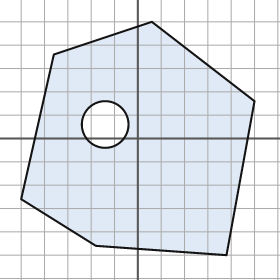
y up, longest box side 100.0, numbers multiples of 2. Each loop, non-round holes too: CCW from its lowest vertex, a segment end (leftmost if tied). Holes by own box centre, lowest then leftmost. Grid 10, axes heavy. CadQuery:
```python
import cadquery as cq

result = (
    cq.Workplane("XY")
    .moveTo(38.0, -50.0)
    .lineTo(50.0, 16.0)
    .lineTo(6.0, 50.0)
    .lineTo(-36.0, 36.0)
    .lineTo(-50.0, -26.0)
    .lineTo(-18.0, -46.0)
    .close()
    .moveTo(-14.0, 6.0)
    .circle(10.0)
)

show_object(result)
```